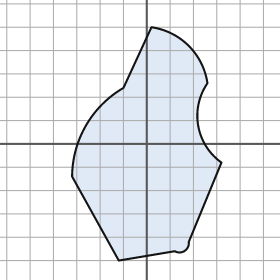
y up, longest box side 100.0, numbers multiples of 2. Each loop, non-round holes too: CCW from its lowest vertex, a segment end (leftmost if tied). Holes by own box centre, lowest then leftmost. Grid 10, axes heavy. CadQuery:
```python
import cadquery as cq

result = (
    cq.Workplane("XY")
    .moveTo(-12.0, -50.0)
    .lineTo(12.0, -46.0)
    .threePointArc((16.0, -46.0), (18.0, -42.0))
    .lineTo(32.0, -8.0)
    .threePointArc((22.0, 8.0), (26.0, 26.0))
    .threePointArc((18.0, 42.0), (2.0, 50.0))
    .lineTo(-10.0, 24.0)
    .threePointArc((-26.0, 8.0), (-32.0, -14.0))
    .close()
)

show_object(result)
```